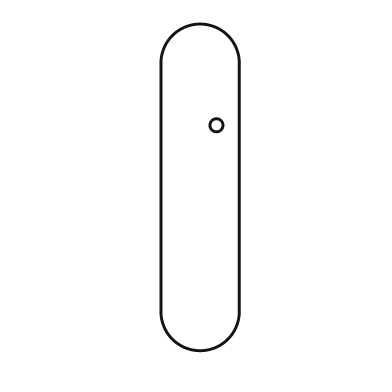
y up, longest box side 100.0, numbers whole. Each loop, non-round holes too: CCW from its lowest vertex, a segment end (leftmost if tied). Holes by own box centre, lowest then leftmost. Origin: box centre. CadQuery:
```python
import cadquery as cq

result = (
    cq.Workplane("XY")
    .moveTo(-12.0, -38.0)
    .threePointArc((0.0, -50.0), (12.0, -38.0))
    .lineTo(12.0, 38.0)
    .threePointArc((0.0, 50.0), (-12.0, 38.0))
    .close()
    .moveTo(5.0, 19.0)
    .circle(2.0)
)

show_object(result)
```